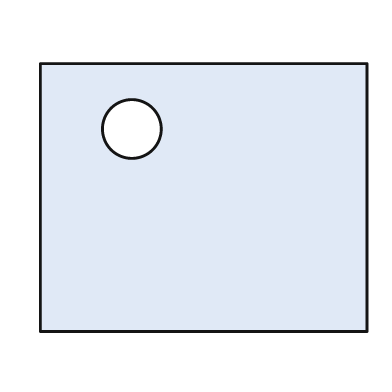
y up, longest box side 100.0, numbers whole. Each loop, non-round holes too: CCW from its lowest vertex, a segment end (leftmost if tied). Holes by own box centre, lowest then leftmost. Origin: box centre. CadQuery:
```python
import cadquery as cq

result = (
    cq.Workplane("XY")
    .moveTo(-50.0, -41.0)
    .lineTo(50.0, -41.0)
    .lineTo(50.0, 41.0)
    .lineTo(-50.0, 41.0)
    .close()
    .moveTo(-22.0, 21.0)
    .circle(9.0)
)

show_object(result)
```